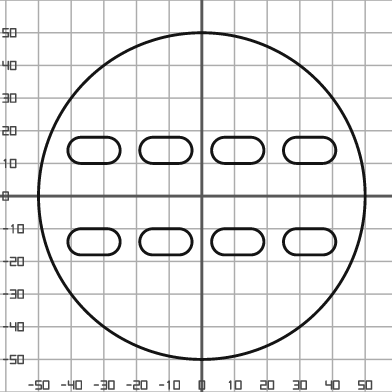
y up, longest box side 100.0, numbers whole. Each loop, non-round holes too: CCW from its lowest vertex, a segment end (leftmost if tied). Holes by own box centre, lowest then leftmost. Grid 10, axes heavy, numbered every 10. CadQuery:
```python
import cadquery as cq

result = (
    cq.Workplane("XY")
    .moveTo(0.0, 0.0)
    .circle(50.0)
    .moveTo(-37.0, -18.0)
    .lineTo(-29.0, -18.0)
    .threePointArc((-25.0, -14.0), (-29.0, -10.0))
    .lineTo(-37.0, -10.0)
    .threePointArc((-41.0, -14.0), (-37.0, -18.0))
    .close()
    .moveTo(-15.0, -18.0)
    .lineTo(-7.0, -18.0)
    .threePointArc((-3.0, -14.0), (-7.0, -10.0))
    .lineTo(-15.0, -10.0)
    .threePointArc((-19.0, -14.0), (-15.0, -18.0))
    .close()
    .moveTo(7.0, -18.0)
    .lineTo(15.0, -18.0)
    .threePointArc((19.0, -14.0), (15.0, -10.0))
    .lineTo(7.0, -10.0)
    .threePointArc((3.0, -14.0), (7.0, -18.0))
    .close()
    .moveTo(29.0, -18.0)
    .lineTo(37.0, -18.0)
    .threePointArc((41.0, -14.0), (37.0, -10.0))
    .lineTo(29.0, -10.0)
    .threePointArc((25.0, -14.0), (29.0, -18.0))
    .close()
    .moveTo(-37.0, 10.0)
    .lineTo(-29.0, 10.0)
    .threePointArc((-25.0, 14.0), (-29.0, 18.0))
    .lineTo(-37.0, 18.0)
    .threePointArc((-41.0, 14.0), (-37.0, 10.0))
    .close()
    .moveTo(-15.0, 10.0)
    .lineTo(-7.0, 10.0)
    .threePointArc((-3.0, 14.0), (-7.0, 18.0))
    .lineTo(-15.0, 18.0)
    .threePointArc((-19.0, 14.0), (-15.0, 10.0))
    .close()
    .moveTo(7.0, 10.0)
    .lineTo(15.0, 10.0)
    .threePointArc((19.0, 14.0), (15.0, 18.0))
    .lineTo(7.0, 18.0)
    .threePointArc((3.0, 14.0), (7.0, 10.0))
    .close()
    .moveTo(29.0, 10.0)
    .lineTo(37.0, 10.0)
    .threePointArc((41.0, 14.0), (37.0, 18.0))
    .lineTo(29.0, 18.0)
    .threePointArc((25.0, 14.0), (29.0, 10.0))
    .close()
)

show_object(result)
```